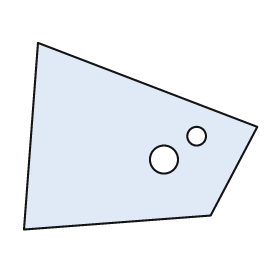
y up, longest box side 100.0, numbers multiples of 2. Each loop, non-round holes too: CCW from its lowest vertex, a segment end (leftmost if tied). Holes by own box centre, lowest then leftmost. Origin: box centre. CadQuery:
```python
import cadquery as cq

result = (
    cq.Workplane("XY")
    .moveTo(-50.0, -40.0)
    .lineTo(30.0, -34.0)
    .lineTo(50.0, 4.0)
    .lineTo(-44.0, 40.0)
    .close()
    .moveTo(10.0, -10.0)
    .circle(6.0)
    .moveTo(24.0, 0.0)
    .circle(4.0)
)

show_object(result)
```